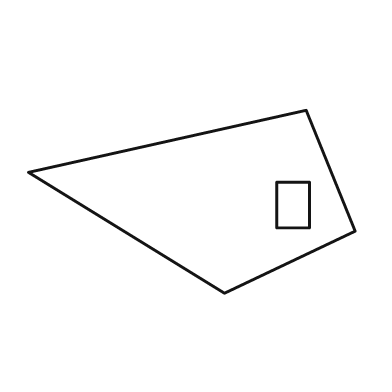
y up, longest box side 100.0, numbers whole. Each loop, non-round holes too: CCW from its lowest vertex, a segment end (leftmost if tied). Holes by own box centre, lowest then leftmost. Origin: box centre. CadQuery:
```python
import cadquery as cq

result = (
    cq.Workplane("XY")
    .moveTo(10.0, -28.0)
    .lineTo(50.0, -9.0)
    .lineTo(35.0, 28.0)
    .lineTo(-50.0, 9.0)
    .close()
    .moveTo(26.0, -8.0)
    .lineTo(36.0, -8.0)
    .lineTo(36.0, 6.0)
    .lineTo(26.0, 6.0)
    .close()
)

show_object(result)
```